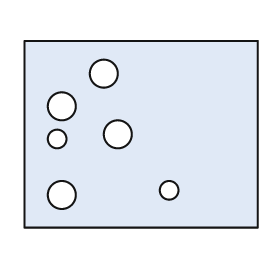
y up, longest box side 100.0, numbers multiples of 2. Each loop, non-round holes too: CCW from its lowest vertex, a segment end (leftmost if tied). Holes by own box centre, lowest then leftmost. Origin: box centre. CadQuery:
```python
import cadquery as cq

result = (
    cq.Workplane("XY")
    .moveTo(-50.0, -40.0)
    .lineTo(50.0, -40.0)
    .lineTo(50.0, 40.0)
    .lineTo(-50.0, 40.0)
    .close()
    .moveTo(-34.0, -26.0)
    .circle(6.0)
    .moveTo(12.0, -24.0)
    .circle(4.0)
    .moveTo(-36.0, -2.0)
    .circle(4.0)
    .moveTo(-10.0, 0.0)
    .circle(6.0)
    .moveTo(-34.0, 12.0)
    .circle(6.0)
    .moveTo(-16.0, 26.0)
    .circle(6.0)
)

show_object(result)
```